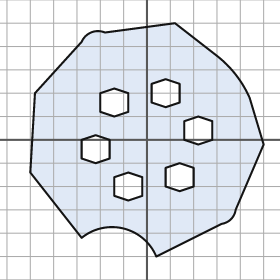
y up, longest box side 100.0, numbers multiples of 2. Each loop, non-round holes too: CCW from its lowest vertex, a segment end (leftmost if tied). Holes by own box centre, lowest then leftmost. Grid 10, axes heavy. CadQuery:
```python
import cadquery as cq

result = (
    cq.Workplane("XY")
    .moveTo(4.0, -50.0)
    .lineTo(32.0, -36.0)
    .threePointArc((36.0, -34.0), (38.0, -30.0))
    .lineTo(50.0, -2.0)
    .lineTo(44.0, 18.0)
    .threePointArc((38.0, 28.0), (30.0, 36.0))
    .lineTo(12.0, 50.0)
    .lineTo(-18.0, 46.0)
    .threePointArc((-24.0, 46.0), (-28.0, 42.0))
    .lineTo(-48.0, 20.0)
    .lineTo(-50.0, -14.0)
    .lineTo(-28.0, -42.0)
    .threePointArc((-10.0, -38.0), (4.0, -50.0))
    .close()
    .moveTo(-8.0, -26.0)
    .lineTo(-2.0, -24.0)
    .lineTo(-2.0, -16.0)
    .lineTo(-8.0, -14.0)
    .lineTo(-14.0, -16.0)
    .lineTo(-14.0, -24.0)
    .close()
    .moveTo(14.0, -22.0)
    .lineTo(20.0, -20.0)
    .lineTo(20.0, -12.0)
    .lineTo(14.0, -10.0)
    .lineTo(8.0, -12.0)
    .lineTo(8.0, -20.0)
    .close()
    .moveTo(-22.0, -10.0)
    .lineTo(-16.0, -8.0)
    .lineTo(-16.0, 0.0)
    .lineTo(-22.0, 2.0)
    .lineTo(-28.0, 0.0)
    .lineTo(-28.0, -8.0)
    .close()
    .moveTo(22.0, -2.0)
    .lineTo(28.0, 0.0)
    .lineTo(28.0, 8.0)
    .lineTo(22.0, 10.0)
    .lineTo(16.0, 8.0)
    .lineTo(16.0, 0.0)
    .close()
    .moveTo(-14.0, 10.0)
    .lineTo(-8.0, 12.0)
    .lineTo(-8.0, 20.0)
    .lineTo(-14.0, 22.0)
    .lineTo(-20.0, 20.0)
    .lineTo(-20.0, 12.0)
    .close()
    .moveTo(8.0, 14.0)
    .lineTo(14.0, 16.0)
    .lineTo(14.0, 24.0)
    .lineTo(8.0, 26.0)
    .lineTo(2.0, 24.0)
    .lineTo(2.0, 16.0)
    .close()
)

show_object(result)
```